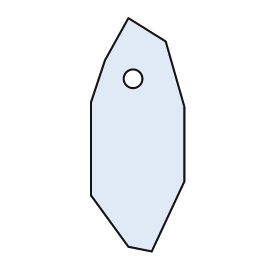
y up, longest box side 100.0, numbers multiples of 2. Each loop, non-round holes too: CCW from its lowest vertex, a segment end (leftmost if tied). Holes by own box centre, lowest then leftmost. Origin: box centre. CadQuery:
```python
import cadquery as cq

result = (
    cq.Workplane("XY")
    .moveTo(6.0, -50.0)
    .lineTo(20.0, -20.0)
    .lineTo(20.0, 12.0)
    .lineTo(12.0, 40.0)
    .lineTo(-4.0, 50.0)
    .lineTo(-14.0, 32.0)
    .lineTo(-20.0, 14.0)
    .lineTo(-20.0, -26.0)
    .lineTo(-4.0, -48.0)
    .close()
    .moveTo(-2.0, 24.0)
    .circle(4.0)
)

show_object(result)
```